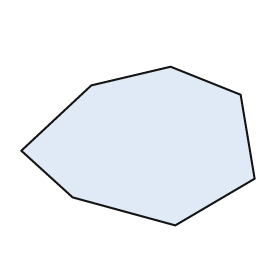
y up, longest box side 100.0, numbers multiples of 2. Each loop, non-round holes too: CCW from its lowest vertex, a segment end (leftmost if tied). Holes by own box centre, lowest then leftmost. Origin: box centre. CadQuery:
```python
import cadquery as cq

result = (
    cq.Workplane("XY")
    .moveTo(16.0, -34.0)
    .lineTo(50.0, -14.0)
    .lineTo(44.0, 22.0)
    .lineTo(14.0, 34.0)
    .lineTo(-20.0, 26.0)
    .lineTo(-50.0, -2.0)
    .lineTo(-28.0, -22.0)
    .close()
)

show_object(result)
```